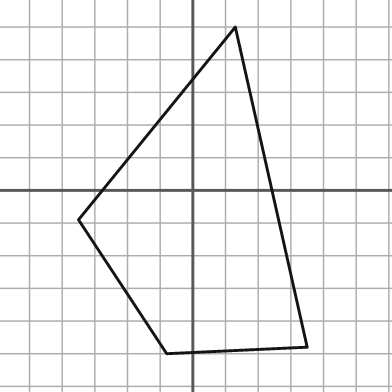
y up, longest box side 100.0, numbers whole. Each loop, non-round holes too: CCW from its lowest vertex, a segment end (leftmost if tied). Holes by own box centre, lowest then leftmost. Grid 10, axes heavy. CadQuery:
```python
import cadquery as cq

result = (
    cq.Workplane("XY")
    .moveTo(-8.0, -50.0)
    .lineTo(35.0, -48.0)
    .lineTo(13.0, 50.0)
    .lineTo(-35.0, -9.0)
    .close()
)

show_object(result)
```